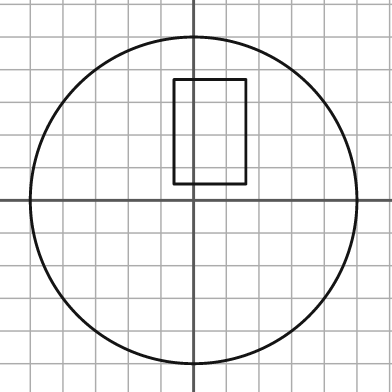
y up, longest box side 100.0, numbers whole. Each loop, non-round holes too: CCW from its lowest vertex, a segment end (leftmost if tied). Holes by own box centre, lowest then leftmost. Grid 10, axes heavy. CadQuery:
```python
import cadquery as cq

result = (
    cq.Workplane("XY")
    .moveTo(0.0, 0.0)
    .circle(50.0)
    .moveTo(-6.0, 5.0)
    .lineTo(16.0, 5.0)
    .lineTo(16.0, 37.0)
    .lineTo(-6.0, 37.0)
    .close()
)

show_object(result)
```